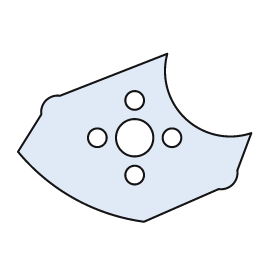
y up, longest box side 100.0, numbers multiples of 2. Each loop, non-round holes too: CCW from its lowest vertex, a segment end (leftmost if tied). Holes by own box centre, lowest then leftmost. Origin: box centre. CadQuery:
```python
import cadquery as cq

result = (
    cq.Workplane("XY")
    .moveTo(4.0, -36.0)
    .lineTo(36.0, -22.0)
    .threePointArc((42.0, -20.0), (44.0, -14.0))
    .lineTo(50.0, 2.0)
    .threePointArc((22.0, 8.0), (14.0, 36.0))
    .lineTo(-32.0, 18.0)
    .threePointArc((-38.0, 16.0), (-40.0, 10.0))
    .lineTo(-50.0, -6.0)
    .threePointArc((-26.0, -26.0), (4.0, -36.0))
    .close()
    .moveTo(0.0, -16.0)
    .circle(4.0)
    .moveTo(-16.0, 0.0)
    .circle(4.0)
    .moveTo(0.0, 0.0)
    .circle(8.0)
    .moveTo(16.0, 0.0)
    .circle(4.0)
    .moveTo(0.0, 16.0)
    .circle(4.0)
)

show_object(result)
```